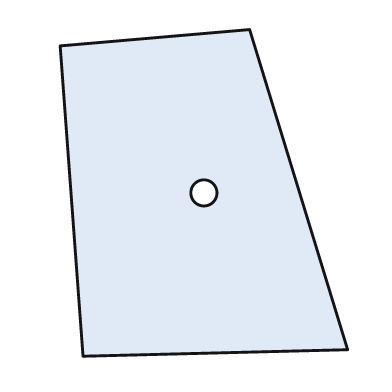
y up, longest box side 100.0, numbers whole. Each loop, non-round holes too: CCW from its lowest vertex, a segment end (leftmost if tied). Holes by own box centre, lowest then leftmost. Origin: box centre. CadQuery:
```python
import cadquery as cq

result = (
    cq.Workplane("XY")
    .moveTo(-37.0, -50.0)
    .lineTo(44.0, -48.0)
    .lineTo(14.0, 50.0)
    .lineTo(-44.0, 45.0)
    .close()
    .moveTo(0.0, 0.0)
    .circle(4.0)
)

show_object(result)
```